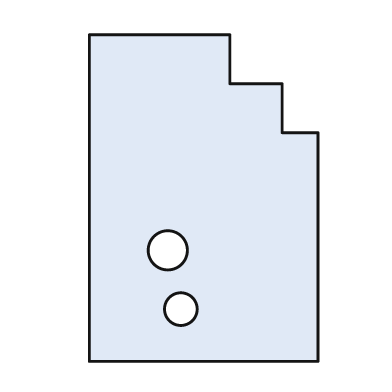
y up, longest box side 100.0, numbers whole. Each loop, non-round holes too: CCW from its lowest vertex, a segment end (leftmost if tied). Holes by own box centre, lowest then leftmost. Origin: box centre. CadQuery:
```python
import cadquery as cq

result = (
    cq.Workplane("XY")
    .moveTo(-35.0, -50.0)
    .lineTo(35.0, -50.0)
    .lineTo(35.0, 20.0)
    .lineTo(24.0, 20.0)
    .lineTo(24.0, 35.0)
    .lineTo(8.0, 35.0)
    .lineTo(8.0, 50.0)
    .lineTo(-35.0, 50.0)
    .close()
    .moveTo(-7.0, -34.0)
    .circle(5.0)
    .moveTo(-11.0, -16.0)
    .circle(6.0)
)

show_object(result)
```